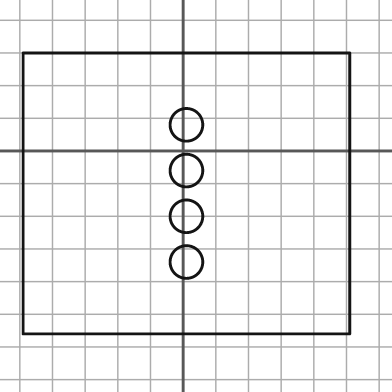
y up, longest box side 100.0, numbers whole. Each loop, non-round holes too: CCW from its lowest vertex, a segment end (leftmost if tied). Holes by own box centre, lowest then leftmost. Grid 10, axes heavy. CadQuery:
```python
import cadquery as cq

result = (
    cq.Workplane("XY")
    .moveTo(-49.0, -56.0)
    .lineTo(51.0, -56.0)
    .lineTo(51.0, 30.0)
    .lineTo(-49.0, 30.0)
    .close()
    .moveTo(1.0, -34.0)
    .circle(5.0)
    .moveTo(1.0, -20.0)
    .circle(5.0)
    .moveTo(1.0, -6.0)
    .circle(5.0)
    .moveTo(1.0, 8.0)
    .circle(5.0)
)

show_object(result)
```